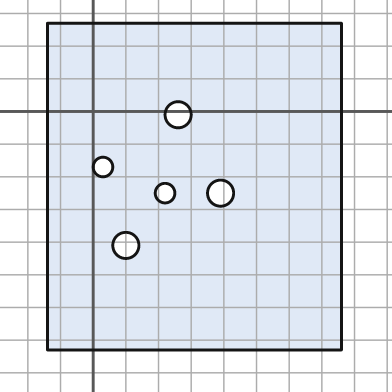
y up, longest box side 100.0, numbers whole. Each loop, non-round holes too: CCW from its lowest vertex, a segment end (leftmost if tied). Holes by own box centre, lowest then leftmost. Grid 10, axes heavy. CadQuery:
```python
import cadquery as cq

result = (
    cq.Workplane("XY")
    .moveTo(-14.0, -73.0)
    .lineTo(76.0, -73.0)
    .lineTo(76.0, 27.0)
    .lineTo(-14.0, 27.0)
    .close()
    .moveTo(10.0, -41.0)
    .circle(4.0)
    .moveTo(22.0, -25.0)
    .circle(3.0)
    .moveTo(39.0, -25.0)
    .circle(4.0)
    .moveTo(3.0, -17.0)
    .circle(3.0)
    .moveTo(26.0, -1.0)
    .circle(4.0)
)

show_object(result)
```